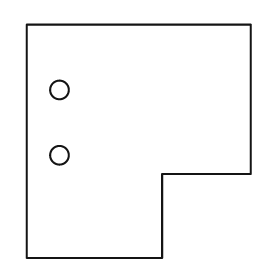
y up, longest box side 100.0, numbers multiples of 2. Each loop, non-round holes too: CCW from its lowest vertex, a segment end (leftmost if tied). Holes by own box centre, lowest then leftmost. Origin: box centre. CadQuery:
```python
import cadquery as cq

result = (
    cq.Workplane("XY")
    .moveTo(-48.0, -50.0)
    .lineTo(10.0, -50.0)
    .lineTo(10.0, -14.0)
    .lineTo(48.0, -14.0)
    .lineTo(48.0, 50.0)
    .lineTo(-48.0, 50.0)
    .close()
    .moveTo(-34.0, -6.0)
    .circle(4.0)
    .moveTo(-34.0, 22.0)
    .circle(4.0)
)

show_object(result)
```